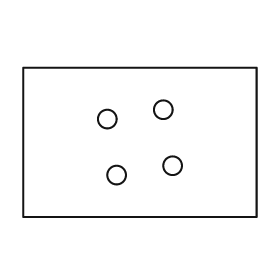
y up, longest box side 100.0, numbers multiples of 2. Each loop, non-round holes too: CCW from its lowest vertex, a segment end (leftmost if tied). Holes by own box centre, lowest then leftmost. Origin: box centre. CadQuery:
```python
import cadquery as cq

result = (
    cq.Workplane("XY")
    .moveTo(-50.0, -32.0)
    .lineTo(50.0, -32.0)
    .lineTo(50.0, 32.0)
    .lineTo(-50.0, 32.0)
    .close()
    .moveTo(-10.0, -14.0)
    .circle(4.0)
    .moveTo(14.0, -10.0)
    .circle(4.0)
    .moveTo(-14.0, 10.0)
    .circle(4.0)
    .moveTo(10.0, 14.0)
    .circle(4.0)
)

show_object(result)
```